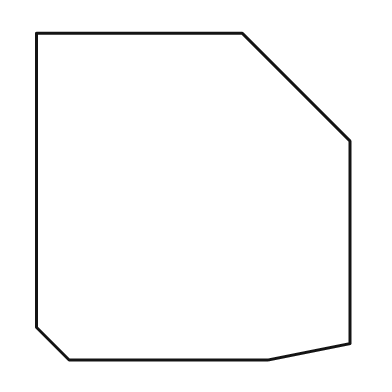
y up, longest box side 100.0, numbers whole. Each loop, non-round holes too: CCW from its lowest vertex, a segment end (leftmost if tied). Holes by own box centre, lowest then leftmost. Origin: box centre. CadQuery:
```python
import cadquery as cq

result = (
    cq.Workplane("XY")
    .moveTo(-38.0, -50.0)
    .lineTo(23.0, -50.0)
    .lineTo(48.0, -45.0)
    .lineTo(48.0, 17.0)
    .lineTo(15.0, 50.0)
    .lineTo(-48.0, 50.0)
    .lineTo(-48.0, -40.0)
    .close()
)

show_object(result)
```